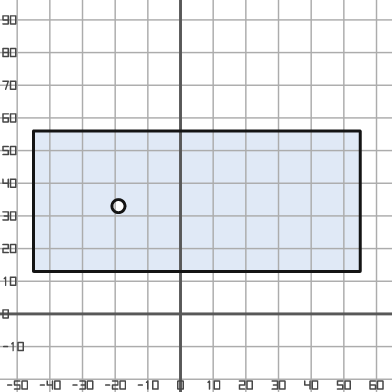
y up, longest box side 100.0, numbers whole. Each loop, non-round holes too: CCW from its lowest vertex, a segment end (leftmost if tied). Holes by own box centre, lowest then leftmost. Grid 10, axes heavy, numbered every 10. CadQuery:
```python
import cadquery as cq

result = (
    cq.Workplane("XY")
    .moveTo(-45.0, 13.0)
    .lineTo(55.0, 13.0)
    .lineTo(55.0, 56.0)
    .lineTo(-45.0, 56.0)
    .close()
    .moveTo(-19.0, 33.0)
    .circle(2.0)
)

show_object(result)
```